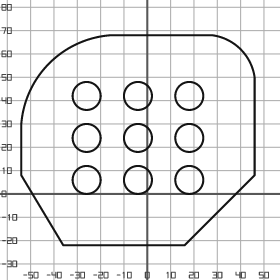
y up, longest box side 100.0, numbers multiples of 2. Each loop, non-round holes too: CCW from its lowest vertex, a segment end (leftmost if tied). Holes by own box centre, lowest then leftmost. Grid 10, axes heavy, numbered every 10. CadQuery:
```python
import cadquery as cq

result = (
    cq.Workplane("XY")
    .moveTo(-36.0, -22.0)
    .lineTo(16.0, -22.0)
    .lineTo(46.0, 8.0)
    .lineTo(46.0, 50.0)
    .threePointArc((40.0, 62.0), (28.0, 68.0))
    .lineTo(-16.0, 68.0)
    .threePointArc((-42.0, 56.0), (-54.0, 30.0))
    .lineTo(-54.0, 8.0)
    .close()
    .moveTo(-26.0, 6.0)
    .circle(6.0)
    .moveTo(-4.0, 6.0)
    .circle(6.0)
    .moveTo(18.0, 6.0)
    .circle(6.0)
    .moveTo(-26.0, 24.0)
    .circle(6.0)
    .moveTo(-4.0, 24.0)
    .circle(6.0)
    .moveTo(18.0, 24.0)
    .circle(6.0)
    .moveTo(-26.0, 42.0)
    .circle(6.0)
    .moveTo(-4.0, 42.0)
    .circle(6.0)
    .moveTo(18.0, 42.0)
    .circle(6.0)
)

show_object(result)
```